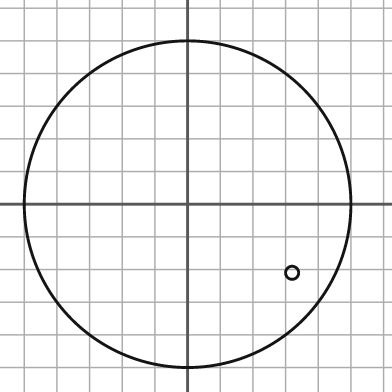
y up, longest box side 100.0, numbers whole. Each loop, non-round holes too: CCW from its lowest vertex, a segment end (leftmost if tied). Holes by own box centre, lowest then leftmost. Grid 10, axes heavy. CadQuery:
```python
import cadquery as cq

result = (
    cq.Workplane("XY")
    .moveTo(0.0, 0.0)
    .circle(50.0)
    .moveTo(32.0, -21.0)
    .circle(2.0)
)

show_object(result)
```